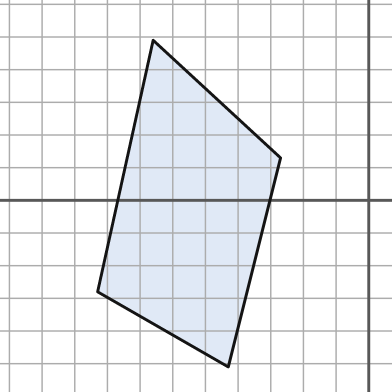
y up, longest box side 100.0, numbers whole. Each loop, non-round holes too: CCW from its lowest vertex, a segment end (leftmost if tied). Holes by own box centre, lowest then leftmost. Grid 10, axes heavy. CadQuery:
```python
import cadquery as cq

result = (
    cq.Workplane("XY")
    .moveTo(-43.0, -51.0)
    .lineTo(-27.0, 13.0)
    .lineTo(-66.0, 49.0)
    .lineTo(-83.0, -28.0)
    .close()
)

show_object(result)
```